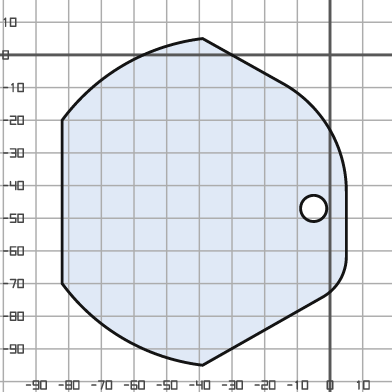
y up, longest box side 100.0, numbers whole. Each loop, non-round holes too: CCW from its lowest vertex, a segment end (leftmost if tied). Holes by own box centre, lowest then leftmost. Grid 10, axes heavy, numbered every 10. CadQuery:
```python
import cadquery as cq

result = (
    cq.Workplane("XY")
    .moveTo(-39.0, -95.0)
    .lineTo(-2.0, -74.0)
    .threePointArc((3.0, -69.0), (5.0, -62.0))
    .lineTo(5.0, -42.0)
    .threePointArc((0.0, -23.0), (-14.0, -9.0))
    .lineTo(-39.0, 5.0)
    .threePointArc((-63.0, -3.0), (-82.0, -20.0))
    .lineTo(-82.0, -70.0)
    .threePointArc((-63.0, -87.0), (-39.0, -95.0))
    .close()
    .moveTo(-5.0, -47.0)
    .circle(4.0)
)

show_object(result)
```